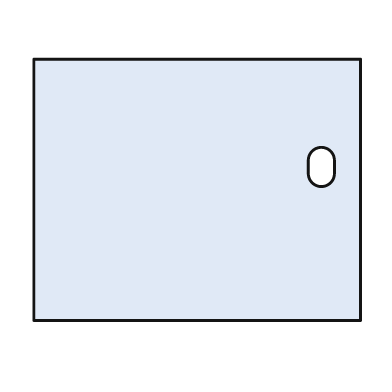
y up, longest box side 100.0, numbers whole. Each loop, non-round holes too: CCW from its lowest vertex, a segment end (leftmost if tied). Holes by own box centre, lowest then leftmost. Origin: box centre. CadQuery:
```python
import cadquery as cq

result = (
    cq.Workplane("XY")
    .moveTo(-50.0, -40.0)
    .lineTo(50.0, -40.0)
    .lineTo(50.0, 40.0)
    .lineTo(-50.0, 40.0)
    .close()
    .moveTo(34.0, 5.0)
    .threePointArc((38.0, 1.0), (42.0, 5.0))
    .lineTo(42.0, 9.0)
    .threePointArc((38.0, 13.0), (34.0, 9.0))
    .close()
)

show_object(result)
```